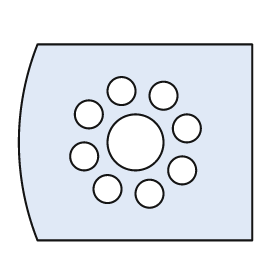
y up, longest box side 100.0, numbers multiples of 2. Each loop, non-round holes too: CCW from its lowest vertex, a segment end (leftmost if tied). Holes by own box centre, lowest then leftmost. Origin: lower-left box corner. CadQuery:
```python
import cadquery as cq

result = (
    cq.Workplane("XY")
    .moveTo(8.0, 0.0)
    .lineTo(100.0, 0.0)
    .lineTo(100.0, 84.0)
    .lineTo(8.0, 84.0)
    .threePointArc((0.0, 42.0), (8.0, 0.0))
    .close()
    .moveTo(56.0, 20.0)
    .circle(6.0)
    .moveTo(38.0, 22.0)
    .circle(6.0)
    .moveTo(70.0, 30.0)
    .circle(6.0)
    .moveTo(28.0, 36.0)
    .circle(6.0)
    .moveTo(50.0, 42.0)
    .circle(12.0)
    .moveTo(72.0, 48.0)
    .circle(6.0)
    .moveTo(30.0, 54.0)
    .circle(6.0)
    .moveTo(62.0, 62.0)
    .circle(6.0)
    .moveTo(44.0, 64.0)
    .circle(6.0)
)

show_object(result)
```